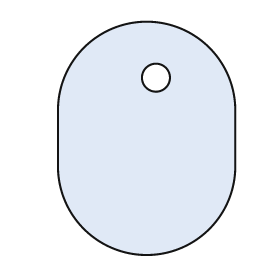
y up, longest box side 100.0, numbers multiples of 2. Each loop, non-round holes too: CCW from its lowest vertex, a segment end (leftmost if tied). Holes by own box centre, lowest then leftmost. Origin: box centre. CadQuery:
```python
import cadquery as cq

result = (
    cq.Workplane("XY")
    .moveTo(-38.0, -12.0)
    .threePointArc((0.0, -50.0), (38.0, -12.0))
    .lineTo(38.0, 12.0)
    .threePointArc((0.0, 50.0), (-38.0, 12.0))
    .close()
    .moveTo(4.0, 26.0)
    .circle(6.0)
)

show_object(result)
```